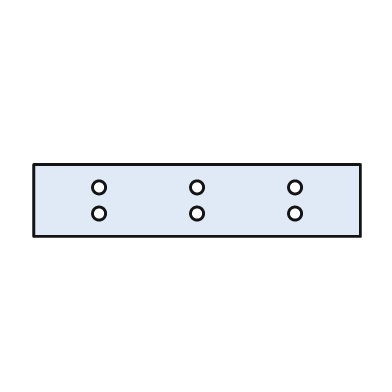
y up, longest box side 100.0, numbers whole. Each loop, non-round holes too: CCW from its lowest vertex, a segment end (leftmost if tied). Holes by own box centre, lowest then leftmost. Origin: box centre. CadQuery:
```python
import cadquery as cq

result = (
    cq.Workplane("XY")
    .moveTo(-50.0, -11.0)
    .lineTo(50.0, -11.0)
    .lineTo(50.0, 11.0)
    .lineTo(-50.0, 11.0)
    .close()
    .moveTo(-30.0, -4.0)
    .circle(2.0)
    .moveTo(0.0, -4.0)
    .circle(2.0)
    .moveTo(30.0, -4.0)
    .circle(2.0)
    .moveTo(-30.0, 4.0)
    .circle(2.0)
    .moveTo(0.0, 4.0)
    .circle(2.0)
    .moveTo(30.0, 4.0)
    .circle(2.0)
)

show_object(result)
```